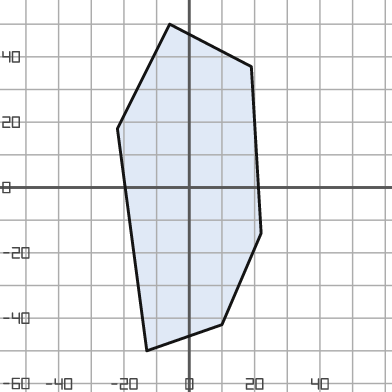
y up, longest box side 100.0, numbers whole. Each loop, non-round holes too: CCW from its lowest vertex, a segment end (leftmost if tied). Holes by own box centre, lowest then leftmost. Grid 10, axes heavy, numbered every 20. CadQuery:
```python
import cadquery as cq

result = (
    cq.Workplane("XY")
    .moveTo(-13.0, -50.0)
    .lineTo(10.0, -42.0)
    .lineTo(22.0, -14.0)
    .lineTo(19.0, 37.0)
    .lineTo(-6.0, 50.0)
    .lineTo(-22.0, 18.0)
    .close()
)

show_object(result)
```